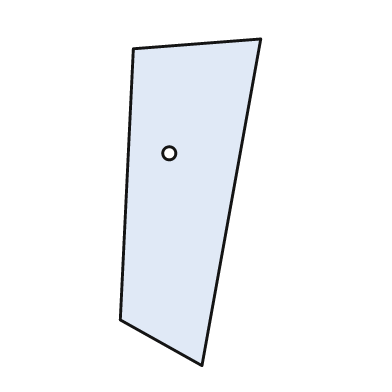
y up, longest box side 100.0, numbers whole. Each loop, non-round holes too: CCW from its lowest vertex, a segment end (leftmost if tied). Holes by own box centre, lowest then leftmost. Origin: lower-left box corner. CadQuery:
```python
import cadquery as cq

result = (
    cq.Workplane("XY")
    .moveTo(25.0, 0.0)
    .lineTo(43.0, 100.0)
    .lineTo(4.0, 97.0)
    .lineTo(0.0, 14.0)
    .close()
    .moveTo(15.0, 65.0)
    .circle(2.0)
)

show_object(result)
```